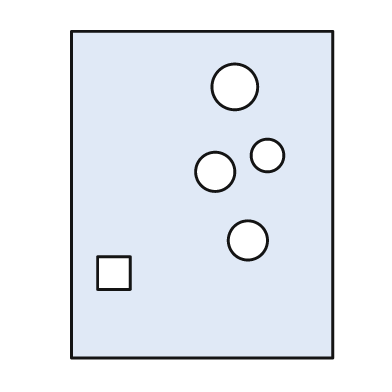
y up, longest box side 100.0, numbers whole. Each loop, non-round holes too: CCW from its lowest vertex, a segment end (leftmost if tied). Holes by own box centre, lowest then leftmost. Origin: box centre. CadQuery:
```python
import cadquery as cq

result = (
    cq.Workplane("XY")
    .moveTo(-40.0, -50.0)
    .lineTo(40.0, -50.0)
    .lineTo(40.0, 50.0)
    .lineTo(-40.0, 50.0)
    .close()
    .moveTo(-32.0, -29.0)
    .lineTo(-22.0, -29.0)
    .lineTo(-22.0, -19.0)
    .lineTo(-32.0, -19.0)
    .close()
    .moveTo(14.0, -14.0)
    .circle(6.0)
    .moveTo(4.0, 7.0)
    .circle(6.0)
    .moveTo(20.0, 12.0)
    .circle(5.0)
    .moveTo(10.0, 33.0)
    .circle(7.0)
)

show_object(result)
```